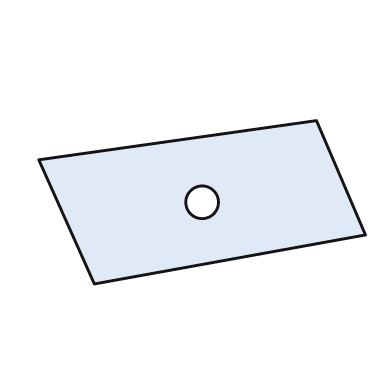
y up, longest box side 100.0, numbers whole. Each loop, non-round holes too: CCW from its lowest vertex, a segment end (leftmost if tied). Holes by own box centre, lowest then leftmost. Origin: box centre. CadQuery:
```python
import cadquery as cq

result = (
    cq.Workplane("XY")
    .moveTo(-33.0, -25.0)
    .lineTo(50.0, -10.0)
    .lineTo(35.0, 25.0)
    .lineTo(-50.0, 13.0)
    .close()
    .moveTo(0.0, 0.0)
    .circle(5.0)
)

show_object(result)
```